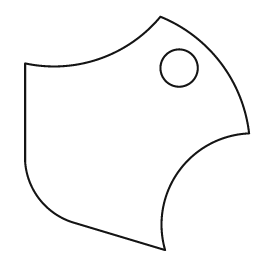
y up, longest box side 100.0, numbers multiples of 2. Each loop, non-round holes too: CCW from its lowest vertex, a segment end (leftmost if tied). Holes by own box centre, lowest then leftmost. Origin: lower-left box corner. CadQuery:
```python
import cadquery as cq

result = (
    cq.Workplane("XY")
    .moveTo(60.0, 0.0)
    .threePointArc((66.0, 34.0), (96.0, 50.0))
    .threePointArc((84.0, 80.0), (58.0, 100.0))
    .threePointArc((32.0, 82.0), (0.0, 80.0))
    .lineTo(0.0, 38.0)
    .threePointArc((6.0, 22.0), (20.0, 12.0))
    .close()
    .moveTo(66.0, 78.0)
    .circle(8.0)
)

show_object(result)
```